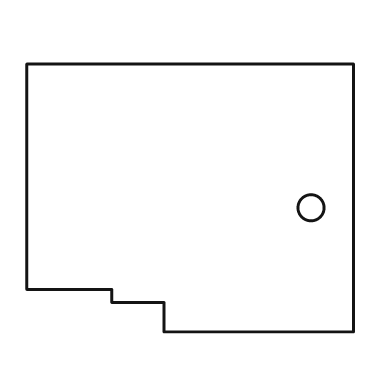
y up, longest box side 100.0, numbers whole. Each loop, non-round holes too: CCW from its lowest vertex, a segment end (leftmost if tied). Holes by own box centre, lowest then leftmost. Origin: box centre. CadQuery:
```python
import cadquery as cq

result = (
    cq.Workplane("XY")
    .moveTo(-8.0, -41.0)
    .lineTo(50.0, -41.0)
    .lineTo(50.0, 41.0)
    .lineTo(-50.0, 41.0)
    .lineTo(-50.0, -28.0)
    .lineTo(-24.0, -28.0)
    .lineTo(-24.0, -32.0)
    .lineTo(-8.0, -32.0)
    .close()
    .moveTo(37.0, -3.0)
    .circle(4.0)
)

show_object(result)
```